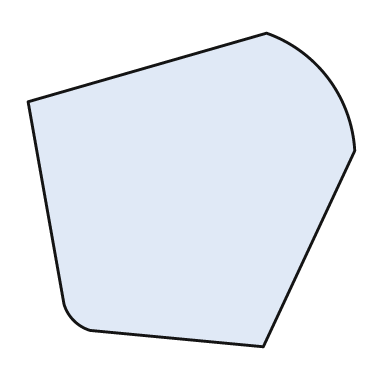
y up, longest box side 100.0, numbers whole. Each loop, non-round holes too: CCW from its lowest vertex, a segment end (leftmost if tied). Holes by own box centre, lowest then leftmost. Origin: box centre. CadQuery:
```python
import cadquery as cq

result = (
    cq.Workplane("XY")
    .moveTo(22.0, -48.0)
    .lineTo(50.0, 12.0)
    .threePointArc((42.0, 34.0), (23.0, 48.0))
    .lineTo(-50.0, 27.0)
    .lineTo(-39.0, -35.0)
    .threePointArc((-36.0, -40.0), (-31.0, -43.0))
    .close()
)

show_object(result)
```